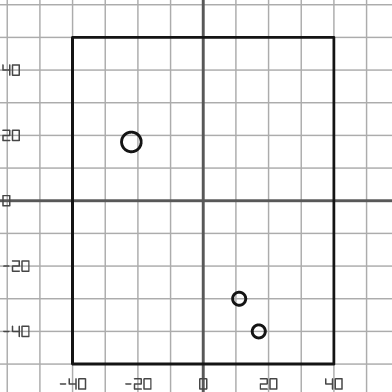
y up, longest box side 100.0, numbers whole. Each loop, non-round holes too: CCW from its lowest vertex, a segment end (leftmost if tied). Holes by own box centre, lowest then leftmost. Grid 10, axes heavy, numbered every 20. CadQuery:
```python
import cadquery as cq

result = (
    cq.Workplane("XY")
    .moveTo(-40.0, -50.0)
    .lineTo(40.0, -50.0)
    .lineTo(40.0, 50.0)
    .lineTo(-40.0, 50.0)
    .close()
    .moveTo(17.0, -40.0)
    .circle(2.0)
    .moveTo(11.0, -30.0)
    .circle(2.0)
    .moveTo(-22.0, 18.0)
    .circle(3.0)
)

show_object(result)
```